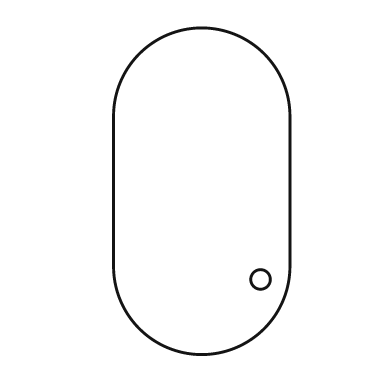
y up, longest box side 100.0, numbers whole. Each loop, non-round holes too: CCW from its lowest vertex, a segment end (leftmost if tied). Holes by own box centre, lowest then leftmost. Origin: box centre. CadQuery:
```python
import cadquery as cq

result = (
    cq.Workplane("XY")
    .moveTo(-27.0, -23.0)
    .threePointArc((0.0, -50.0), (27.0, -23.0))
    .lineTo(27.0, 23.0)
    .threePointArc((0.0, 50.0), (-27.0, 23.0))
    .close()
    .moveTo(18.0, -27.0)
    .circle(3.0)
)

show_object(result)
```